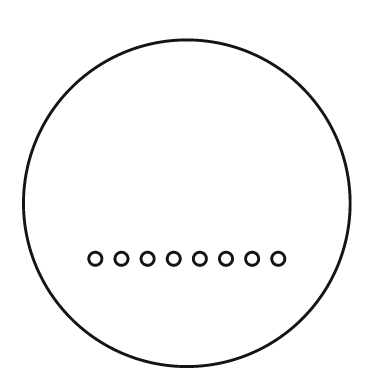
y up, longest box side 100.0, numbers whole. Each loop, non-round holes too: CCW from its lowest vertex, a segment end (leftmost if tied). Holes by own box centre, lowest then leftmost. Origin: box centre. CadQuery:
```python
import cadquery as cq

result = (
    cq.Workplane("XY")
    .moveTo(0.0, 0.0)
    .circle(50.0)
    .moveTo(-28.0, -17.0)
    .circle(2.0)
    .moveTo(-20.0, -17.0)
    .circle(2.0)
    .moveTo(-12.0, -17.0)
    .circle(2.0)
    .moveTo(-4.0, -17.0)
    .circle(2.0)
    .moveTo(4.0, -17.0)
    .circle(2.0)
    .moveTo(12.0, -17.0)
    .circle(2.0)
    .moveTo(20.0, -17.0)
    .circle(2.0)
    .moveTo(28.0, -17.0)
    .circle(2.0)
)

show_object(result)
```